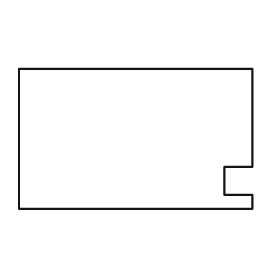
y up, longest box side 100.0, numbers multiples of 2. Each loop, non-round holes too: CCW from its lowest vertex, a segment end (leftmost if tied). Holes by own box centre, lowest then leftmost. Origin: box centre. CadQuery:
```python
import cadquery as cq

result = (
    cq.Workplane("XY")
    .moveTo(-50.0, -30.0)
    .lineTo(50.0, -30.0)
    .lineTo(50.0, -24.0)
    .lineTo(38.0, -24.0)
    .lineTo(38.0, -12.0)
    .lineTo(50.0, -12.0)
    .lineTo(50.0, 30.0)
    .lineTo(-50.0, 30.0)
    .close()
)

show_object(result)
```